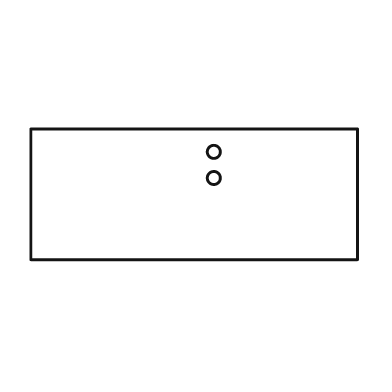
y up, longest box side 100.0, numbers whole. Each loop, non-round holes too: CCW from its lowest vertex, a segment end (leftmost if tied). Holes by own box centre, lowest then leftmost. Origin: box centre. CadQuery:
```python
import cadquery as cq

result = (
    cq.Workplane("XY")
    .moveTo(-50.0, -20.0)
    .lineTo(50.0, -20.0)
    .lineTo(50.0, 20.0)
    .lineTo(-50.0, 20.0)
    .close()
    .moveTo(6.0, 5.0)
    .circle(2.0)
    .moveTo(6.0, 13.0)
    .circle(2.0)
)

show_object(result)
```